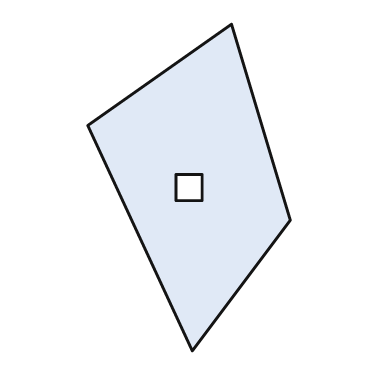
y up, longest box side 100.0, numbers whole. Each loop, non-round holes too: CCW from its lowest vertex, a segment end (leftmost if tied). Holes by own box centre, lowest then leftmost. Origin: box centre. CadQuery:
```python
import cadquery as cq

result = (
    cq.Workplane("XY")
    .moveTo(1.0, -50.0)
    .lineTo(31.0, -10.0)
    .lineTo(13.0, 50.0)
    .lineTo(-31.0, 19.0)
    .close()
    .moveTo(-4.0, -4.0)
    .lineTo(4.0, -4.0)
    .lineTo(4.0, 4.0)
    .lineTo(-4.0, 4.0)
    .close()
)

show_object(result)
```